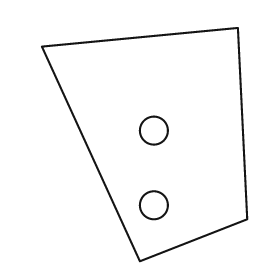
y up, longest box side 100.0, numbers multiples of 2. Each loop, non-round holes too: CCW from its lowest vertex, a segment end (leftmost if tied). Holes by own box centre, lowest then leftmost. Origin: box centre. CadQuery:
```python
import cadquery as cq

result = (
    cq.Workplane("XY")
    .moveTo(-2.0, -50.0)
    .lineTo(44.0, -32.0)
    .lineTo(40.0, 50.0)
    .lineTo(-44.0, 42.0)
    .close()
    .moveTo(4.0, -26.0)
    .circle(6.0)
    .moveTo(4.0, 6.0)
    .circle(6.0)
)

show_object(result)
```